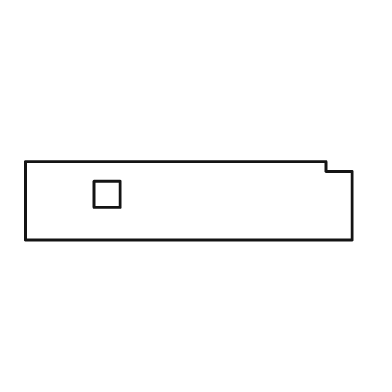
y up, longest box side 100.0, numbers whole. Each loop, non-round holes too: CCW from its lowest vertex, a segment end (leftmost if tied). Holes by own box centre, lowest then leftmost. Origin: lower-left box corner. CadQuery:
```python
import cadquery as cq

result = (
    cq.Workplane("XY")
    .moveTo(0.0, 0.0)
    .lineTo(100.0, 0.0)
    .lineTo(100.0, 21.0)
    .lineTo(92.0, 21.0)
    .lineTo(92.0, 24.0)
    .lineTo(0.0, 24.0)
    .close()
    .moveTo(21.0, 10.0)
    .lineTo(29.0, 10.0)
    .lineTo(29.0, 18.0)
    .lineTo(21.0, 18.0)
    .close()
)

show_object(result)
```